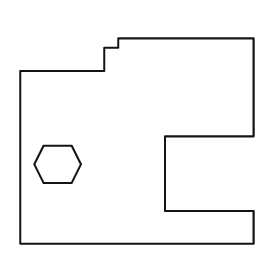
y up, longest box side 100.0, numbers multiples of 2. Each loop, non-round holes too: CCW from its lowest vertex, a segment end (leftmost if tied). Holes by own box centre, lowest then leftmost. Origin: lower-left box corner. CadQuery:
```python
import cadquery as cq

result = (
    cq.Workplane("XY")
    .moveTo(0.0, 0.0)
    .lineTo(100.0, 0.0)
    .lineTo(100.0, 14.0)
    .lineTo(62.0, 14.0)
    .lineTo(62.0, 46.0)
    .lineTo(100.0, 46.0)
    .lineTo(100.0, 88.0)
    .lineTo(42.0, 88.0)
    .lineTo(42.0, 84.0)
    .lineTo(36.0, 84.0)
    .lineTo(36.0, 74.0)
    .lineTo(0.0, 74.0)
    .close()
    .moveTo(10.0, 26.0)
    .lineTo(22.0, 26.0)
    .lineTo(26.0, 34.0)
    .lineTo(22.0, 42.0)
    .lineTo(10.0, 42.0)
    .lineTo(6.0, 34.0)
    .close()
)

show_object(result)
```